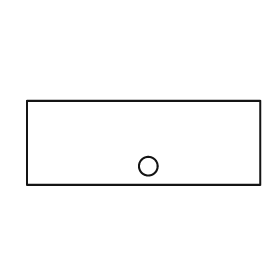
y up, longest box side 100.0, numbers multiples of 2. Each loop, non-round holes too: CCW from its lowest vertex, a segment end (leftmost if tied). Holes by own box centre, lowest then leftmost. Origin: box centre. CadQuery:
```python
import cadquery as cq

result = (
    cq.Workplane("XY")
    .moveTo(-50.0, -18.0)
    .lineTo(50.0, -18.0)
    .lineTo(50.0, 18.0)
    .lineTo(-50.0, 18.0)
    .close()
    .moveTo(2.0, -10.0)
    .circle(4.0)
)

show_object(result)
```